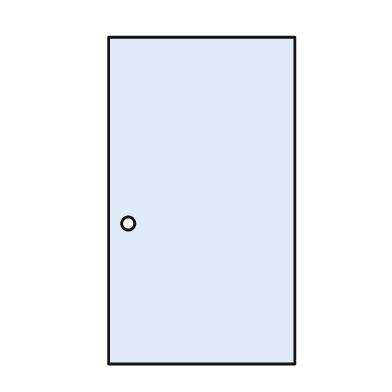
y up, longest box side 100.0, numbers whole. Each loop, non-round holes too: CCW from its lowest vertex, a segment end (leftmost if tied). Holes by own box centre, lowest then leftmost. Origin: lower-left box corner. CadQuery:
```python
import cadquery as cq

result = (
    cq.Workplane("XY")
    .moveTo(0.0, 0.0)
    .lineTo(57.0, 0.0)
    .lineTo(57.0, 100.0)
    .lineTo(0.0, 100.0)
    .close()
    .moveTo(6.0, 43.0)
    .circle(2.0)
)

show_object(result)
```